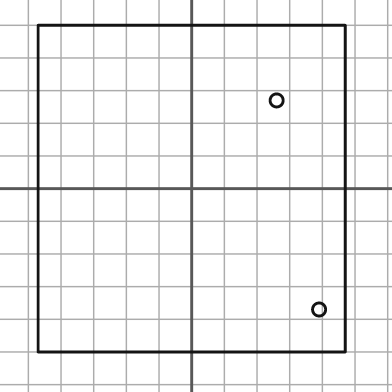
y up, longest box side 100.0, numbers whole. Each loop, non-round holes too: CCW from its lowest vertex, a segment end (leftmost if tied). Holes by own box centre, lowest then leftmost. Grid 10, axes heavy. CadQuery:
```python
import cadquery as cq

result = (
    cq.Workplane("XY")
    .moveTo(-47.0, -50.0)
    .lineTo(47.0, -50.0)
    .lineTo(47.0, 50.0)
    .lineTo(-47.0, 50.0)
    .close()
    .moveTo(39.0, -37.0)
    .circle(2.0)
    .moveTo(26.0, 27.0)
    .circle(2.0)
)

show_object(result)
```